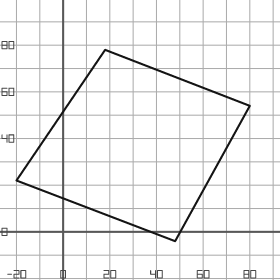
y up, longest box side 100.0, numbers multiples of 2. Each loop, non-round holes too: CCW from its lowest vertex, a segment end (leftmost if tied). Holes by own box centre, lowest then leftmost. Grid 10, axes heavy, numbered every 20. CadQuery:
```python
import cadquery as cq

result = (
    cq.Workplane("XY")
    .moveTo(48.0, -4.0)
    .lineTo(80.0, 54.0)
    .lineTo(18.0, 78.0)
    .lineTo(-20.0, 22.0)
    .close()
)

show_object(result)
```